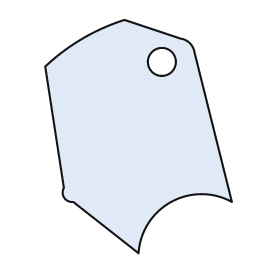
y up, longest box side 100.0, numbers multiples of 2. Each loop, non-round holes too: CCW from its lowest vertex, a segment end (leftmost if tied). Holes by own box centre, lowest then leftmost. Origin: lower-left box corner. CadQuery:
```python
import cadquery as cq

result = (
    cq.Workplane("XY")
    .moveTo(40.0, 0.0)
    .threePointArc((54.0, 22.0), (80.0, 22.0))
    .lineTo(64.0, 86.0)
    .threePointArc((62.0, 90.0), (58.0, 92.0))
    .lineTo(34.0, 100.0)
    .threePointArc((16.0, 92.0), (0.0, 80.0))
    .lineTo(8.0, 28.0)
    .threePointArc((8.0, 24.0), (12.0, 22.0))
    .close()
    .moveTo(50.0, 82.0)
    .circle(6.0)
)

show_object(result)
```